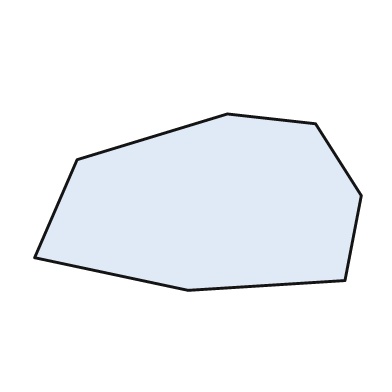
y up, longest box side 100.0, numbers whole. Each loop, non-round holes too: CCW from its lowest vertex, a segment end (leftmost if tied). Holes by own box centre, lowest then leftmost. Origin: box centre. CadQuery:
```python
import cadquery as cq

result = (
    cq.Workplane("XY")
    .moveTo(-3.0, -27.0)
    .lineTo(45.0, -24.0)
    .lineTo(50.0, 2.0)
    .lineTo(36.0, 24.0)
    .lineTo(9.0, 27.0)
    .lineTo(-37.0, 13.0)
    .lineTo(-50.0, -17.0)
    .close()
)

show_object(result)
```